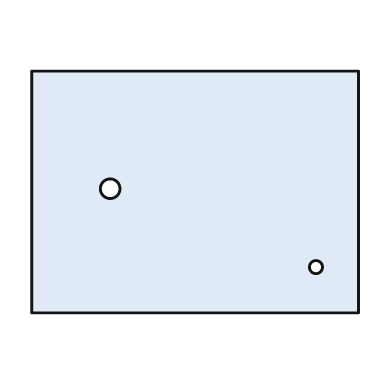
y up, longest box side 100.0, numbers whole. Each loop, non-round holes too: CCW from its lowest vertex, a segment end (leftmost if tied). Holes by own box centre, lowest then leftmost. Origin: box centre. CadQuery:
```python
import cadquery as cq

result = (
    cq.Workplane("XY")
    .moveTo(-50.0, -37.0)
    .lineTo(50.0, -37.0)
    .lineTo(50.0, 37.0)
    .lineTo(-50.0, 37.0)
    .close()
    .moveTo(37.0, -23.0)
    .circle(2.0)
    .moveTo(-26.0, 1.0)
    .circle(3.0)
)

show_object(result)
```